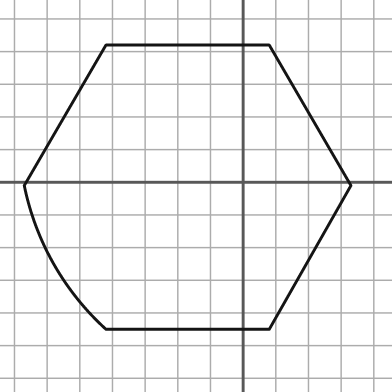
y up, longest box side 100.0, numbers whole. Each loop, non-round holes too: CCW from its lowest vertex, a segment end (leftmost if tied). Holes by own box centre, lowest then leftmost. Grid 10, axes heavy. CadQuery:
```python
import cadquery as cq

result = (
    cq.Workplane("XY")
    .moveTo(-42.0, -45.0)
    .lineTo(8.0, -45.0)
    .lineTo(33.0, -1.0)
    .lineTo(8.0, 42.0)
    .lineTo(-42.0, 42.0)
    .lineTo(-67.0, -1.0)
    .threePointArc((-58.0, -25.0), (-42.0, -45.0))
    .close()
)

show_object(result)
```